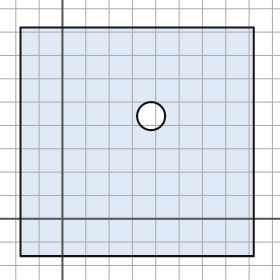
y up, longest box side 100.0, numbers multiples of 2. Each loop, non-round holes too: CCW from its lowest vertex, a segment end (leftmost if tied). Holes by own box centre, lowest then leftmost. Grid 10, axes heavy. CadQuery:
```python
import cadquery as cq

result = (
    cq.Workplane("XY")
    .moveTo(-18.0, -16.0)
    .lineTo(82.0, -16.0)
    .lineTo(82.0, 82.0)
    .lineTo(-18.0, 82.0)
    .close()
    .moveTo(38.0, 44.0)
    .circle(6.0)
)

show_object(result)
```